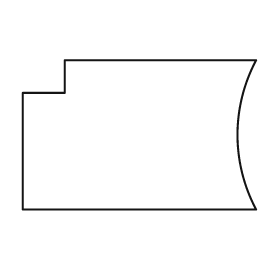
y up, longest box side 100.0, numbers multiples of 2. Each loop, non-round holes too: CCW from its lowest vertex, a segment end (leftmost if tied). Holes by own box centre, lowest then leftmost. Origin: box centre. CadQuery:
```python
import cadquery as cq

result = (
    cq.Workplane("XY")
    .moveTo(-50.0, -32.0)
    .lineTo(50.0, -32.0)
    .threePointArc((42.0, 0.0), (50.0, 32.0))
    .lineTo(-32.0, 32.0)
    .lineTo(-32.0, 18.0)
    .lineTo(-50.0, 18.0)
    .close()
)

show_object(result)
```